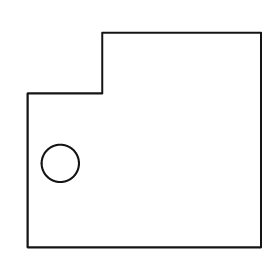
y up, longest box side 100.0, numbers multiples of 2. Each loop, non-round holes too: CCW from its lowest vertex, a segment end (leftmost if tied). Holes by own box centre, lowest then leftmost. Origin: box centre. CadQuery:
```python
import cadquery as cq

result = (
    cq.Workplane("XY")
    .moveTo(-50.0, -46.0)
    .lineTo(50.0, -46.0)
    .lineTo(50.0, 46.0)
    .lineTo(-18.0, 46.0)
    .lineTo(-18.0, 20.0)
    .lineTo(-50.0, 20.0)
    .close()
    .moveTo(-36.0, -10.0)
    .circle(8.0)
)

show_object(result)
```